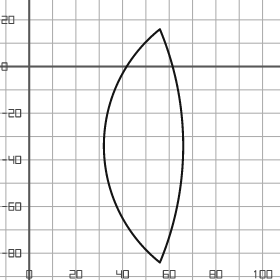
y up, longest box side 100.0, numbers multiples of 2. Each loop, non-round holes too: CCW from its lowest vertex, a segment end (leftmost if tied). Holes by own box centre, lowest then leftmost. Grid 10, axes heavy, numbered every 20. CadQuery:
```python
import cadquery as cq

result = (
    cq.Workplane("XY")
    .moveTo(56.0, -84.0)
    .threePointArc((66.0, -34.0), (56.0, 16.0))
    .threePointArc((32.0, -34.0), (56.0, -84.0))
    .close()
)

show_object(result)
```